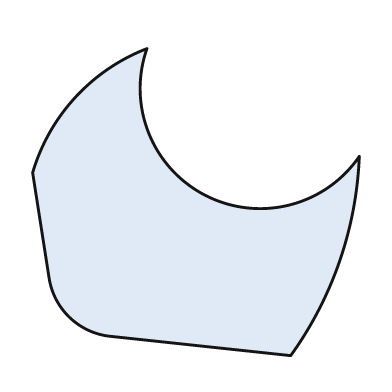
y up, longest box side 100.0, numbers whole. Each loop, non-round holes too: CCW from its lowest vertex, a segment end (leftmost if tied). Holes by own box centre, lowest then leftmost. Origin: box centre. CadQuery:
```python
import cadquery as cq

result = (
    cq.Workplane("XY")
    .moveTo(29.0, -47.0)
    .threePointArc((44.0, -18.0), (50.0, 14.0))
    .threePointArc((3.0, 2.0), (-15.0, 47.0))
    .threePointArc((-37.0, 32.0), (-50.0, 9.0))
    .lineTo(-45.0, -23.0)
    .threePointArc((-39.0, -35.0), (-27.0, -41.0))
    .close()
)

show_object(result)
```